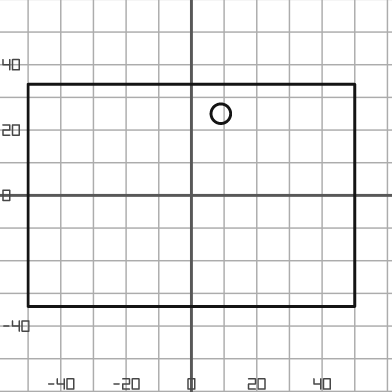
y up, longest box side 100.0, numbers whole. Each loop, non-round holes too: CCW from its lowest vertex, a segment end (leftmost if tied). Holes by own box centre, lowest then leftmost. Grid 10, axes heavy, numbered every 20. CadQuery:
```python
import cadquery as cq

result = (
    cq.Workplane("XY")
    .moveTo(-50.0, -34.0)
    .lineTo(50.0, -34.0)
    .lineTo(50.0, 34.0)
    .lineTo(-50.0, 34.0)
    .close()
    .moveTo(9.0, 25.0)
    .circle(3.0)
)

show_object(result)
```